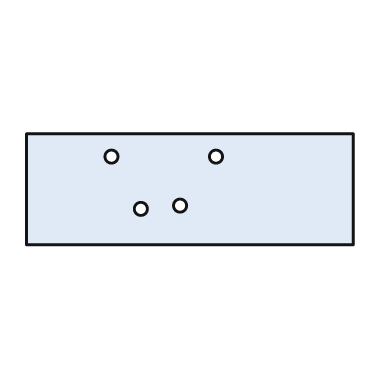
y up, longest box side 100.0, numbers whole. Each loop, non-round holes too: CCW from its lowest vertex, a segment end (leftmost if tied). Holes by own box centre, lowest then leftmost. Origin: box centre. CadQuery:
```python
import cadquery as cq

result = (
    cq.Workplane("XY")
    .moveTo(-50.0, -17.0)
    .lineTo(50.0, -17.0)
    .lineTo(50.0, 17.0)
    .lineTo(-50.0, 17.0)
    .close()
    .moveTo(-15.0, -6.0)
    .circle(2.0)
    .moveTo(-3.0, -5.0)
    .circle(2.0)
    .moveTo(-24.0, 10.0)
    .circle(2.0)
    .moveTo(8.0, 10.0)
    .circle(2.0)
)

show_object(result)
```